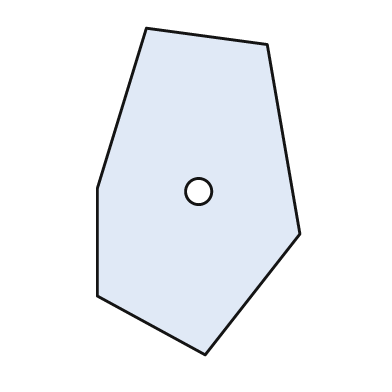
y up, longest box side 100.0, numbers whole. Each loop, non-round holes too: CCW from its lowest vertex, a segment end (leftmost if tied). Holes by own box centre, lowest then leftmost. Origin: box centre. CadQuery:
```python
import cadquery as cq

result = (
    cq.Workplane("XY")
    .moveTo(2.0, -50.0)
    .lineTo(31.0, -13.0)
    .lineTo(21.0, 45.0)
    .lineTo(-16.0, 50.0)
    .lineTo(-31.0, 1.0)
    .lineTo(-31.0, -32.0)
    .close()
    .moveTo(0.0, 0.0)
    .circle(4.0)
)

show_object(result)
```